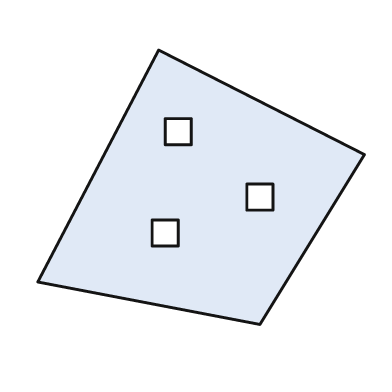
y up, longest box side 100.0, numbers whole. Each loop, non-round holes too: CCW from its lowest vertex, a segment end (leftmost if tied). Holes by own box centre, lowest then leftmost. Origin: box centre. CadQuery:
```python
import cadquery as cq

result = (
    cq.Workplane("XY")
    .moveTo(18.0, -42.0)
    .lineTo(50.0, 10.0)
    .lineTo(-13.0, 42.0)
    .lineTo(-50.0, -29.0)
    .close()
    .moveTo(-15.0, -18.0)
    .lineTo(-7.0, -18.0)
    .lineTo(-7.0, -10.0)
    .lineTo(-15.0, -10.0)
    .close()
    .moveTo(14.0, -7.0)
    .lineTo(22.0, -7.0)
    .lineTo(22.0, 1.0)
    .lineTo(14.0, 1.0)
    .close()
    .moveTo(-11.0, 13.0)
    .lineTo(-3.0, 13.0)
    .lineTo(-3.0, 21.0)
    .lineTo(-11.0, 21.0)
    .close()
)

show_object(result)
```